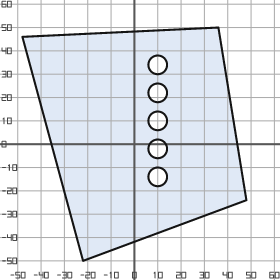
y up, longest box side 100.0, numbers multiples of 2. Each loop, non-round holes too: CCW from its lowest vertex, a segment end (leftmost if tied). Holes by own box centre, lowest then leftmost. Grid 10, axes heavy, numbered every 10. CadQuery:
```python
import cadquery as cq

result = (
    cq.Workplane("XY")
    .moveTo(-22.0, -50.0)
    .lineTo(48.0, -24.0)
    .lineTo(36.0, 50.0)
    .lineTo(-48.0, 46.0)
    .close()
    .moveTo(10.0, -14.0)
    .circle(4.0)
    .moveTo(10.0, -2.0)
    .circle(4.0)
    .moveTo(10.0, 10.0)
    .circle(4.0)
    .moveTo(10.0, 22.0)
    .circle(4.0)
    .moveTo(10.0, 34.0)
    .circle(4.0)
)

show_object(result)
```